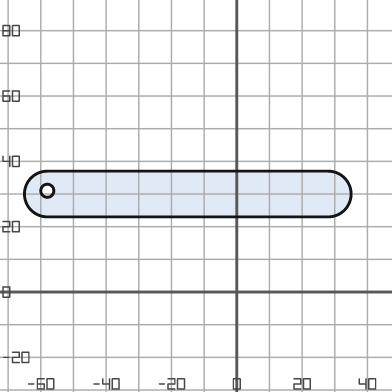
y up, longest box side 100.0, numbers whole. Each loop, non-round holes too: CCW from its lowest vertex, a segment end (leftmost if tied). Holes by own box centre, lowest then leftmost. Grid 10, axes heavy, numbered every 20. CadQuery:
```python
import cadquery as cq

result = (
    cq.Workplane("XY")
    .moveTo(-58.0, 23.0)
    .lineTo(28.0, 23.0)
    .threePointArc((35.0, 30.0), (28.0, 37.0))
    .lineTo(-58.0, 37.0)
    .threePointArc((-65.0, 30.0), (-58.0, 23.0))
    .close()
    .moveTo(-58.0, 31.0)
    .circle(2.0)
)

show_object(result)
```